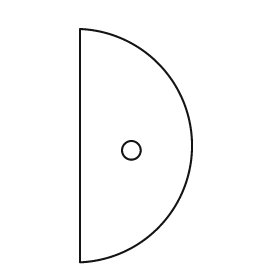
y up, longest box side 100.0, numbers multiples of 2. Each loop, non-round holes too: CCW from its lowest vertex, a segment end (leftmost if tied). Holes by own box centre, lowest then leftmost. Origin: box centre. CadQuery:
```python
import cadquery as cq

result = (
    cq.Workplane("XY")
    .moveTo(-24.0, -50.0)
    .threePointArc((24.0, 0.0), (-24.0, 50.0))
    .close()
    .moveTo(-2.0, -2.0)
    .circle(4.0)
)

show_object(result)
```